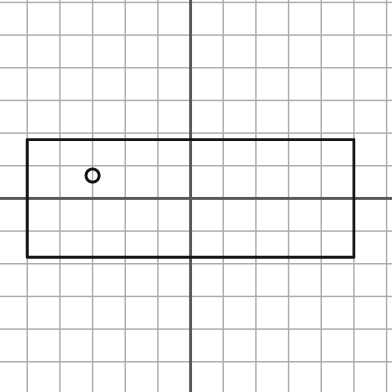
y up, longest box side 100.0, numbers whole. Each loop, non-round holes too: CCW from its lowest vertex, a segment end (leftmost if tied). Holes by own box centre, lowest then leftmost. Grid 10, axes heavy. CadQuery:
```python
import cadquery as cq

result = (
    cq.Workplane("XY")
    .moveTo(-50.0, -18.0)
    .lineTo(50.0, -18.0)
    .lineTo(50.0, 18.0)
    .lineTo(-50.0, 18.0)
    .close()
    .moveTo(-30.0, 7.0)
    .circle(2.0)
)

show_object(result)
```